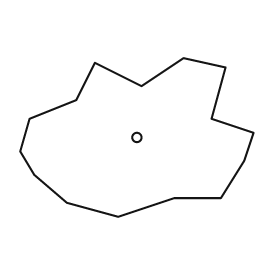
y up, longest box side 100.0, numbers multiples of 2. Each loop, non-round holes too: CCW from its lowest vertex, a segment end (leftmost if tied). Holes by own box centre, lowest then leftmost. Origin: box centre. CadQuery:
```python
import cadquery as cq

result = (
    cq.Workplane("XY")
    .moveTo(-8.0, -34.0)
    .lineTo(16.0, -26.0)
    .lineTo(36.0, -26.0)
    .lineTo(46.0, -10.0)
    .lineTo(50.0, 2.0)
    .lineTo(32.0, 8.0)
    .lineTo(38.0, 30.0)
    .lineTo(20.0, 34.0)
    .lineTo(2.0, 22.0)
    .lineTo(-18.0, 32.0)
    .lineTo(-26.0, 16.0)
    .lineTo(-46.0, 8.0)
    .lineTo(-50.0, -6.0)
    .lineTo(-44.0, -16.0)
    .lineTo(-30.0, -28.0)
    .close()
    .moveTo(0.0, 0.0)
    .circle(2.0)
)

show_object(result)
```